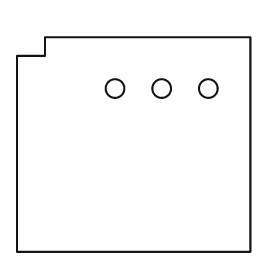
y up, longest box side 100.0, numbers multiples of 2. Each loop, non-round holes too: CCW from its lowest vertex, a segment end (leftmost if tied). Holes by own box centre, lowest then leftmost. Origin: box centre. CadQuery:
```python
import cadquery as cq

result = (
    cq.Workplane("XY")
    .moveTo(-50.0, -46.0)
    .lineTo(50.0, -46.0)
    .lineTo(50.0, 46.0)
    .lineTo(-38.0, 46.0)
    .lineTo(-38.0, 38.0)
    .lineTo(-50.0, 38.0)
    .close()
    .moveTo(-8.0, 24.0)
    .circle(4.0)
    .moveTo(12.0, 24.0)
    .circle(4.0)
    .moveTo(32.0, 24.0)
    .circle(4.0)
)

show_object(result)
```